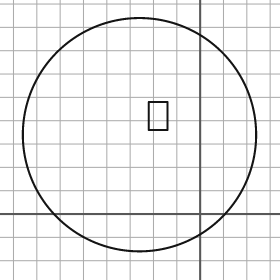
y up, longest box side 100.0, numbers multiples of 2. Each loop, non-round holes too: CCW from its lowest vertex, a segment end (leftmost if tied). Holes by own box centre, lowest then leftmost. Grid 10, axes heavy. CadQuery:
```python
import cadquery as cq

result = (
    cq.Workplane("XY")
    .moveTo(-26.0, 34.0)
    .circle(50.0)
    .moveTo(-22.0, 36.0)
    .lineTo(-14.0, 36.0)
    .lineTo(-14.0, 48.0)
    .lineTo(-22.0, 48.0)
    .close()
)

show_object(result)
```